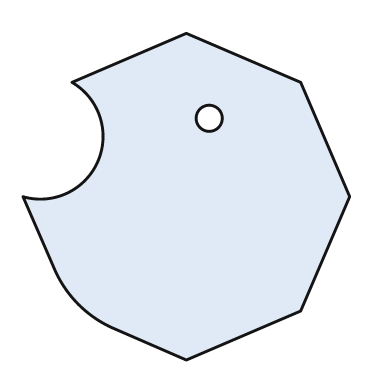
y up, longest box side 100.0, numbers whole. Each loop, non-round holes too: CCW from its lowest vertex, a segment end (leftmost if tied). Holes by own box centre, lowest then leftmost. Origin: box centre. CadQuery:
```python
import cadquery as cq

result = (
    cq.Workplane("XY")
    .moveTo(0.0, -50.0)
    .lineTo(35.0, -35.0)
    .lineTo(50.0, 0.0)
    .lineTo(35.0, 35.0)
    .lineTo(0.0, 50.0)
    .lineTo(-35.0, 35.0)
    .threePointArc((-27.0, 11.0), (-50.0, 0.0))
    .lineTo(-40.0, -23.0)
    .threePointArc((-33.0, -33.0), (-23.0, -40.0))
    .close()
    .moveTo(7.0, 24.0)
    .circle(4.0)
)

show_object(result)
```